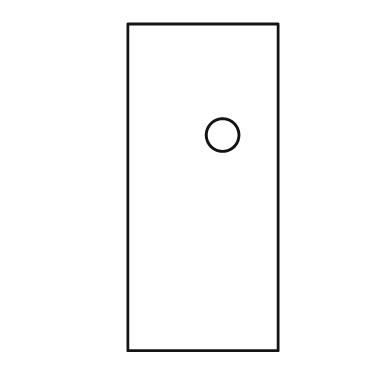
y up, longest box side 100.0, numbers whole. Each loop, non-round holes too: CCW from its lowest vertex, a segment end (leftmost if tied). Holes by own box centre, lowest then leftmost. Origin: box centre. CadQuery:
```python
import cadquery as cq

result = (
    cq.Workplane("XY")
    .moveTo(-23.0, -50.0)
    .lineTo(23.0, -50.0)
    .lineTo(23.0, 50.0)
    .lineTo(-23.0, 50.0)
    .close()
    .moveTo(6.0, 16.0)
    .circle(5.0)
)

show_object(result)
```